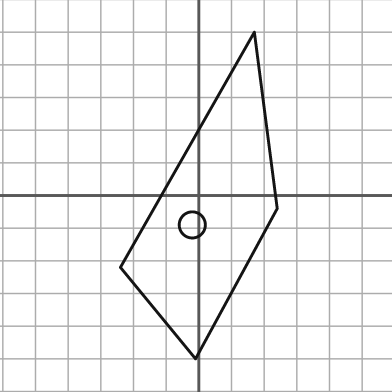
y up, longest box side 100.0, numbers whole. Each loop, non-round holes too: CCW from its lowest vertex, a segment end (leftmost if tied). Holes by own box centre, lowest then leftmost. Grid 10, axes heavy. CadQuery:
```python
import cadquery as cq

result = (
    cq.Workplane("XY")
    .moveTo(-1.0, -50.0)
    .lineTo(24.0, -4.0)
    .lineTo(17.0, 50.0)
    .lineTo(-24.0, -22.0)
    .close()
    .moveTo(-2.0, -9.0)
    .circle(4.0)
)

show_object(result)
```